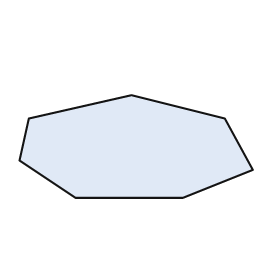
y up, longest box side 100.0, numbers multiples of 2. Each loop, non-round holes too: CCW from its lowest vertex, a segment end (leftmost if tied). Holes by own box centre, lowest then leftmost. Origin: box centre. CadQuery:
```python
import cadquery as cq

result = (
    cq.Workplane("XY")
    .moveTo(-26.0, -22.0)
    .lineTo(20.0, -22.0)
    .lineTo(50.0, -10.0)
    .lineTo(38.0, 12.0)
    .lineTo(-2.0, 22.0)
    .lineTo(-46.0, 12.0)
    .lineTo(-50.0, -6.0)
    .close()
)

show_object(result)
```